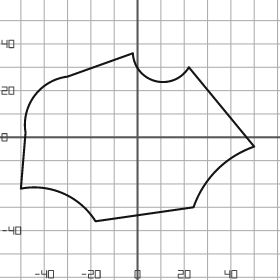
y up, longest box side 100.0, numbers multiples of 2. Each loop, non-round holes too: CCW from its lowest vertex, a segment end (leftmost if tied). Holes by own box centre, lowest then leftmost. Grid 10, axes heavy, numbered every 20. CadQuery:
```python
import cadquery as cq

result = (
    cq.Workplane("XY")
    .moveTo(-18.0, -36.0)
    .lineTo(24.0, -30.0)
    .threePointArc((34.0, -14.0), (50.0, -4.0))
    .lineTo(22.0, 30.0)
    .threePointArc((8.0, 24.0), (-2.0, 36.0))
    .lineTo(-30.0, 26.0)
    .threePointArc((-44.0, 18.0), (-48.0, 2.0))
    .lineTo(-50.0, -22.0)
    .threePointArc((-32.0, -24.0), (-18.0, -36.0))
    .close()
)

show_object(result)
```